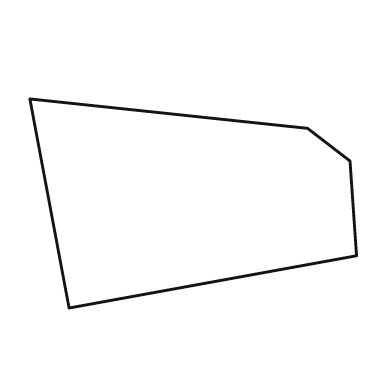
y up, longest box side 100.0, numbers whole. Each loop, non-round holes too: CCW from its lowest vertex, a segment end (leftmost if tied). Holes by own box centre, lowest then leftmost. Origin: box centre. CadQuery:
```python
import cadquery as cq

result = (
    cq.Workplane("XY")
    .moveTo(-38.0, -32.0)
    .lineTo(50.0, -16.0)
    .lineTo(48.0, 13.0)
    .lineTo(35.0, 23.0)
    .lineTo(-50.0, 32.0)
    .close()
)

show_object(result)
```